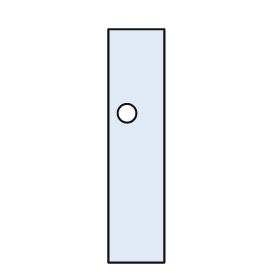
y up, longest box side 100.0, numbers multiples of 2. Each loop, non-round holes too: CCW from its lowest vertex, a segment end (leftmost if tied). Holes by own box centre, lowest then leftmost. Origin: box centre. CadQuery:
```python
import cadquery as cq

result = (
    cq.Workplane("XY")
    .moveTo(-12.0, -50.0)
    .lineTo(12.0, -50.0)
    .lineTo(12.0, 50.0)
    .lineTo(-12.0, 50.0)
    .close()
    .moveTo(-4.0, 14.0)
    .circle(4.0)
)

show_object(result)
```